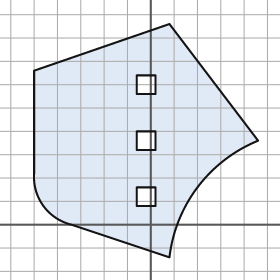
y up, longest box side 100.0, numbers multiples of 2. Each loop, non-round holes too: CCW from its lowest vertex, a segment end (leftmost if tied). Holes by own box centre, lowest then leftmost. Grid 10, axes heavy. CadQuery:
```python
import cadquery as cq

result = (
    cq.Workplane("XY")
    .moveTo(8.0, -14.0)
    .threePointArc((20.0, 16.0), (46.0, 36.0))
    .lineTo(8.0, 86.0)
    .lineTo(-50.0, 66.0)
    .lineTo(-50.0, 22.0)
    .threePointArc((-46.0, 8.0), (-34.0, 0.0))
    .close()
    .moveTo(-6.0, 8.0)
    .lineTo(2.0, 8.0)
    .lineTo(2.0, 16.0)
    .lineTo(-6.0, 16.0)
    .close()
    .moveTo(-6.0, 32.0)
    .lineTo(2.0, 32.0)
    .lineTo(2.0, 40.0)
    .lineTo(-6.0, 40.0)
    .close()
    .moveTo(-6.0, 56.0)
    .lineTo(2.0, 56.0)
    .lineTo(2.0, 64.0)
    .lineTo(-6.0, 64.0)
    .close()
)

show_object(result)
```